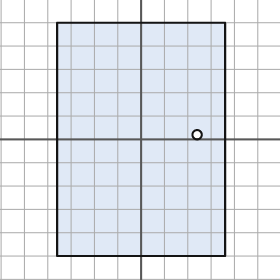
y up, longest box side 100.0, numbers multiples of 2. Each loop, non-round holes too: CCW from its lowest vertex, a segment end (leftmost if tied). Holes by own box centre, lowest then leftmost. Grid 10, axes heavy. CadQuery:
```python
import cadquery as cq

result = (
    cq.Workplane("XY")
    .moveTo(-36.0, -50.0)
    .lineTo(36.0, -50.0)
    .lineTo(36.0, 50.0)
    .lineTo(-36.0, 50.0)
    .close()
    .moveTo(24.0, 2.0)
    .circle(2.0)
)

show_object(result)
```